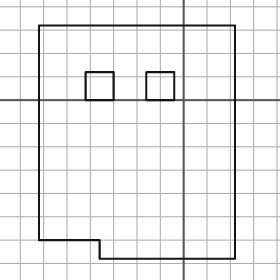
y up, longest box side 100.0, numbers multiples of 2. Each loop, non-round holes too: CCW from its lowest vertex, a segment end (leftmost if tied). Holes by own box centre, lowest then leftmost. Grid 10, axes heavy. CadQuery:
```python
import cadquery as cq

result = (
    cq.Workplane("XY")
    .moveTo(-36.0, -68.0)
    .lineTo(22.0, -68.0)
    .lineTo(22.0, 32.0)
    .lineTo(-62.0, 32.0)
    .lineTo(-62.0, -60.0)
    .lineTo(-36.0, -60.0)
    .close()
    .moveTo(-42.0, 0.0)
    .lineTo(-30.0, 0.0)
    .lineTo(-30.0, 12.0)
    .lineTo(-42.0, 12.0)
    .close()
    .moveTo(-16.0, 0.0)
    .lineTo(-4.0, 0.0)
    .lineTo(-4.0, 12.0)
    .lineTo(-16.0, 12.0)
    .close()
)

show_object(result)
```